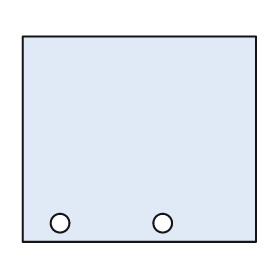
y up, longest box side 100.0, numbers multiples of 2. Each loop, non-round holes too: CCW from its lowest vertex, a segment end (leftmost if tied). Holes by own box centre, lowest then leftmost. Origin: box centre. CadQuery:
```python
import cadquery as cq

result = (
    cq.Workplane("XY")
    .moveTo(-50.0, -44.0)
    .lineTo(50.0, -44.0)
    .lineTo(50.0, 44.0)
    .lineTo(-50.0, 44.0)
    .close()
    .moveTo(-34.0, -36.0)
    .circle(4.0)
    .moveTo(10.0, -36.0)
    .circle(4.0)
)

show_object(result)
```